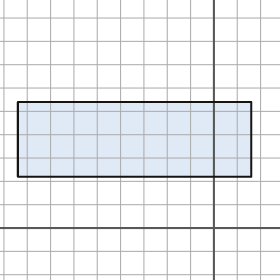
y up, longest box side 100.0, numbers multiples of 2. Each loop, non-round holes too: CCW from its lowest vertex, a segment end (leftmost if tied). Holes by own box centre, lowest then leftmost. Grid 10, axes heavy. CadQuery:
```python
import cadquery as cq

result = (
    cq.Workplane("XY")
    .moveTo(-84.0, 22.0)
    .lineTo(16.0, 22.0)
    .lineTo(16.0, 54.0)
    .lineTo(-84.0, 54.0)
    .close()
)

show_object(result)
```